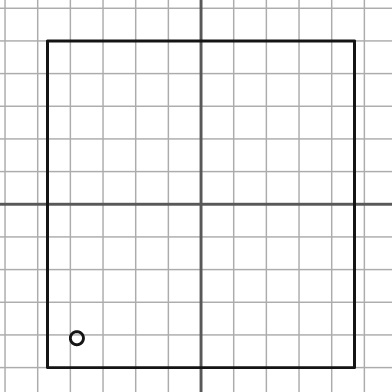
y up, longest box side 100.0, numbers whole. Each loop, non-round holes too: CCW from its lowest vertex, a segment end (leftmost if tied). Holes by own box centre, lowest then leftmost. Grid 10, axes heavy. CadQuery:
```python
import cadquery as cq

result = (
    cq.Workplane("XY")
    .moveTo(-47.0, -50.0)
    .lineTo(47.0, -50.0)
    .lineTo(47.0, 50.0)
    .lineTo(-47.0, 50.0)
    .close()
    .moveTo(-38.0, -41.0)
    .circle(2.0)
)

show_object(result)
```